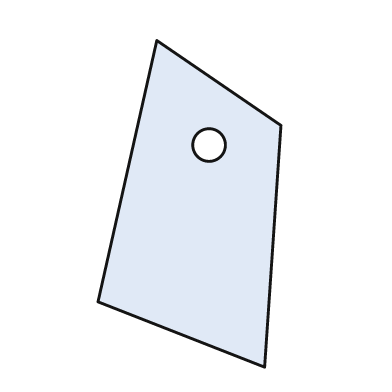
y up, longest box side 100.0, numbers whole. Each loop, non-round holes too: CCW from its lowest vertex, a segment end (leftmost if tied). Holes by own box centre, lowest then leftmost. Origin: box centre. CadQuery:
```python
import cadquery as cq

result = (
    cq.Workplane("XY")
    .moveTo(23.0, -50.0)
    .lineTo(28.0, 24.0)
    .lineTo(-10.0, 50.0)
    .lineTo(-28.0, -30.0)
    .close()
    .moveTo(6.0, 18.0)
    .circle(5.0)
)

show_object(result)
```